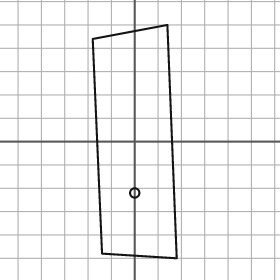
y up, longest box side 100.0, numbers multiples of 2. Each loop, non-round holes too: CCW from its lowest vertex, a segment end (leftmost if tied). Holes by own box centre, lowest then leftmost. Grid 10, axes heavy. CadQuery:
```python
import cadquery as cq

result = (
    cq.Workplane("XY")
    .moveTo(18.0, -50.0)
    .lineTo(14.0, 50.0)
    .lineTo(-18.0, 44.0)
    .lineTo(-14.0, -48.0)
    .close()
    .moveTo(0.0, -22.0)
    .circle(2.0)
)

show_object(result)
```